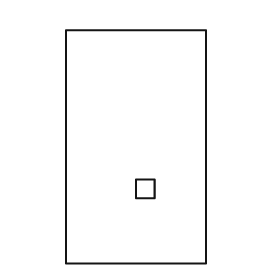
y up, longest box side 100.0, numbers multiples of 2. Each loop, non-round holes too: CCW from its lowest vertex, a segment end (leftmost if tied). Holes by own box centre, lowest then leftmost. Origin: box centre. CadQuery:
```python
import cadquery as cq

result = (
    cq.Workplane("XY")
    .moveTo(-30.0, -50.0)
    .lineTo(30.0, -50.0)
    .lineTo(30.0, 50.0)
    .lineTo(-30.0, 50.0)
    .close()
    .moveTo(0.0, -22.0)
    .lineTo(8.0, -22.0)
    .lineTo(8.0, -14.0)
    .lineTo(0.0, -14.0)
    .close()
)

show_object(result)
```